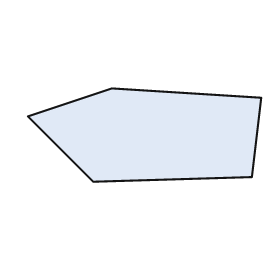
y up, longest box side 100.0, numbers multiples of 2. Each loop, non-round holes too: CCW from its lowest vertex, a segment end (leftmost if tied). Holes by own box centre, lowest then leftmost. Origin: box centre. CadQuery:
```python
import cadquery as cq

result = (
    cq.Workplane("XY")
    .moveTo(-22.0, -20.0)
    .lineTo(46.0, -18.0)
    .lineTo(50.0, 16.0)
    .lineTo(-14.0, 20.0)
    .lineTo(-50.0, 8.0)
    .close()
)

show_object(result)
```